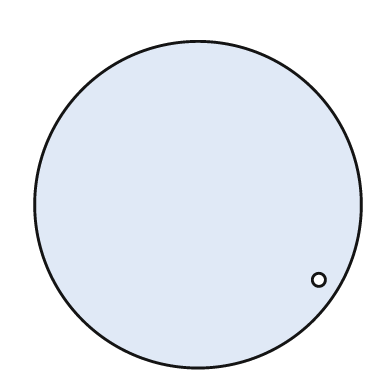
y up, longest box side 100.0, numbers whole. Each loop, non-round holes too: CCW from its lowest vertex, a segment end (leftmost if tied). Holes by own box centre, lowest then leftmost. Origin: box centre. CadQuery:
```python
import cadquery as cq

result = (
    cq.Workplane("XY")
    .moveTo(0.0, 0.0)
    .circle(50.0)
    .moveTo(37.0, -23.0)
    .circle(2.0)
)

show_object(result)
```